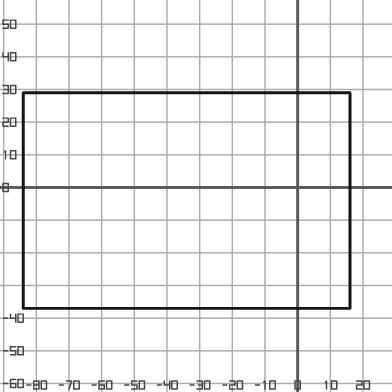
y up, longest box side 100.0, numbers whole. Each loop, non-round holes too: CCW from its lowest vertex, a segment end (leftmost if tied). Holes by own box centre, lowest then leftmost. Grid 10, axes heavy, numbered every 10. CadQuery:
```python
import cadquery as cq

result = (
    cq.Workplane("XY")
    .moveTo(-84.0, -37.0)
    .lineTo(16.0, -37.0)
    .lineTo(16.0, 29.0)
    .lineTo(-84.0, 29.0)
    .close()
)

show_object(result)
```